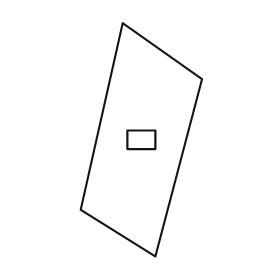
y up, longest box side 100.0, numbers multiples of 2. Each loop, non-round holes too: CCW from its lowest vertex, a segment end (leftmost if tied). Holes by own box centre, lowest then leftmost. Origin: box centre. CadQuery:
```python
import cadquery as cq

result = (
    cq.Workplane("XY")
    .moveTo(6.0, -50.0)
    .lineTo(26.0, 26.0)
    .lineTo(-8.0, 50.0)
    .lineTo(-26.0, -30.0)
    .close()
    .moveTo(-6.0, -4.0)
    .lineTo(6.0, -4.0)
    .lineTo(6.0, 4.0)
    .lineTo(-6.0, 4.0)
    .close()
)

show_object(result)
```